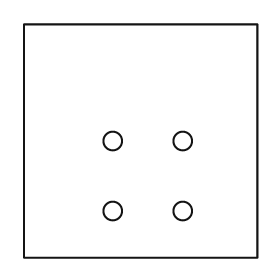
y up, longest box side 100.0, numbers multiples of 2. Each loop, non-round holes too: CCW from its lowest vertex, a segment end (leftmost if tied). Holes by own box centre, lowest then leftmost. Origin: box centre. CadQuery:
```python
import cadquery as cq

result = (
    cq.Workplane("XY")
    .moveTo(-50.0, -50.0)
    .lineTo(50.0, -50.0)
    .lineTo(50.0, 50.0)
    .lineTo(-50.0, 50.0)
    .close()
    .moveTo(-12.0, -30.0)
    .circle(4.0)
    .moveTo(18.0, -30.0)
    .circle(4.0)
    .moveTo(-12.0, 0.0)
    .circle(4.0)
    .moveTo(18.0, 0.0)
    .circle(4.0)
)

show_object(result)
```